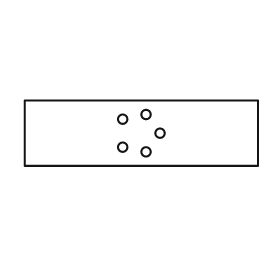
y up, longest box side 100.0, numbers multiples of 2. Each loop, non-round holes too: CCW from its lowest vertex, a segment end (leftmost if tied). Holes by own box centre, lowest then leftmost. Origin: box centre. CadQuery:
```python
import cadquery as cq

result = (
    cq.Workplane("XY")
    .moveTo(-50.0, -14.0)
    .lineTo(50.0, -14.0)
    .lineTo(50.0, 14.0)
    .lineTo(-50.0, 14.0)
    .close()
    .moveTo(2.0, -8.0)
    .circle(2.0)
    .moveTo(-8.0, -6.0)
    .circle(2.0)
    .moveTo(8.0, 0.0)
    .circle(2.0)
    .moveTo(-8.0, 6.0)
    .circle(2.0)
    .moveTo(2.0, 8.0)
    .circle(2.0)
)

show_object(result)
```